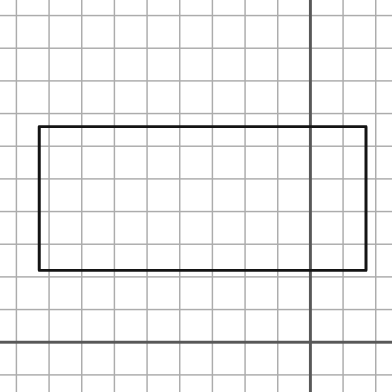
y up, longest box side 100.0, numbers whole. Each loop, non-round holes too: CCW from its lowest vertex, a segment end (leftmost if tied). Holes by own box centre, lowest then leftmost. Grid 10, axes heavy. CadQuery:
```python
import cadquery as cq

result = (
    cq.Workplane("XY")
    .moveTo(-83.0, 22.0)
    .lineTo(17.0, 22.0)
    .lineTo(17.0, 66.0)
    .lineTo(-83.0, 66.0)
    .close()
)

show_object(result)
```